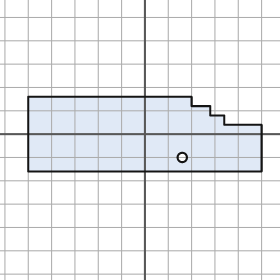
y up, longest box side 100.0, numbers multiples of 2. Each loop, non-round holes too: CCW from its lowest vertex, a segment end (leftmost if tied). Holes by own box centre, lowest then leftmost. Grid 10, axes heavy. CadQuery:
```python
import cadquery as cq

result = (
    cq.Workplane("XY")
    .moveTo(-50.0, -16.0)
    .lineTo(50.0, -16.0)
    .lineTo(50.0, 4.0)
    .lineTo(34.0, 4.0)
    .lineTo(34.0, 8.0)
    .lineTo(28.0, 8.0)
    .lineTo(28.0, 12.0)
    .lineTo(20.0, 12.0)
    .lineTo(20.0, 16.0)
    .lineTo(-50.0, 16.0)
    .close()
    .moveTo(16.0, -10.0)
    .circle(2.0)
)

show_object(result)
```